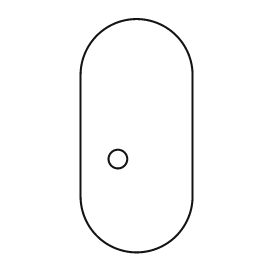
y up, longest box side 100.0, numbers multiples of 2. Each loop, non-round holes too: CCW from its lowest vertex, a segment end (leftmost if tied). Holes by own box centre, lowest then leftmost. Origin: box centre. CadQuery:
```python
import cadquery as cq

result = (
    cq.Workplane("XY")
    .moveTo(-24.0, -26.0)
    .threePointArc((0.0, -50.0), (24.0, -26.0))
    .lineTo(24.0, 26.0)
    .threePointArc((0.0, 50.0), (-24.0, 26.0))
    .close()
    .moveTo(-8.0, -10.0)
    .circle(4.0)
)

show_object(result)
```